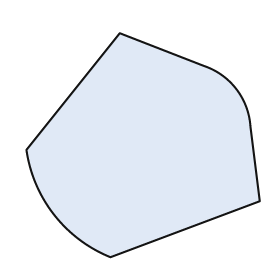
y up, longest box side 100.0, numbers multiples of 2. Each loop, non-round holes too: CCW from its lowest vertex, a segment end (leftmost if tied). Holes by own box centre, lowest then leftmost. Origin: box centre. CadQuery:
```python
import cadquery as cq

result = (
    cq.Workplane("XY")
    .moveTo(-14.0, -48.0)
    .lineTo(50.0, -24.0)
    .lineTo(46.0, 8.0)
    .threePointArc((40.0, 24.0), (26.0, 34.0))
    .lineTo(-10.0, 48.0)
    .lineTo(-50.0, -2.0)
    .threePointArc((-38.0, -30.0), (-14.0, -48.0))
    .close()
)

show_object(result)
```